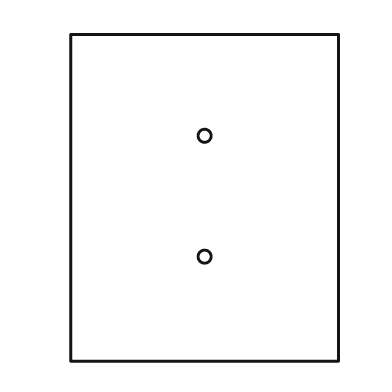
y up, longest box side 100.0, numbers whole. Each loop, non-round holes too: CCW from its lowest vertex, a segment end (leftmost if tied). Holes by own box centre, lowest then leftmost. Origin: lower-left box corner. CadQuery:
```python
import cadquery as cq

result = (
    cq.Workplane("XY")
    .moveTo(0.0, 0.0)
    .lineTo(82.0, 0.0)
    .lineTo(82.0, 100.0)
    .lineTo(0.0, 100.0)
    .close()
    .moveTo(41.0, 32.0)
    .circle(2.0)
    .moveTo(41.0, 69.0)
    .circle(2.0)
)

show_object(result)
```